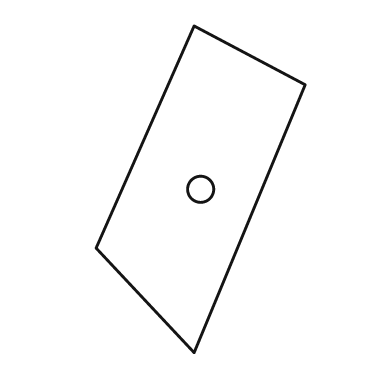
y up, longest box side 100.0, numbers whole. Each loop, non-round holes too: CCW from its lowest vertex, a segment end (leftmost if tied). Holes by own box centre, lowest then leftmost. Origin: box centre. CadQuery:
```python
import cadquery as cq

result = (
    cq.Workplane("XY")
    .moveTo(-2.0, -50.0)
    .lineTo(32.0, 32.0)
    .lineTo(-2.0, 50.0)
    .lineTo(-32.0, -18.0)
    .close()
    .moveTo(0.0, 0.0)
    .circle(4.0)
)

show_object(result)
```